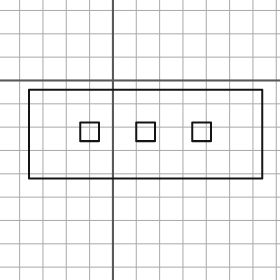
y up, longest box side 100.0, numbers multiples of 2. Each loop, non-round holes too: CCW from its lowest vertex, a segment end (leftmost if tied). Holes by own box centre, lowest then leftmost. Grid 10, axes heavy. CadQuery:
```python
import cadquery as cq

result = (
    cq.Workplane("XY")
    .moveTo(-36.0, -42.0)
    .lineTo(64.0, -42.0)
    .lineTo(64.0, -4.0)
    .lineTo(-36.0, -4.0)
    .close()
    .moveTo(-14.0, -26.0)
    .lineTo(-6.0, -26.0)
    .lineTo(-6.0, -18.0)
    .lineTo(-14.0, -18.0)
    .close()
    .moveTo(10.0, -26.0)
    .lineTo(18.0, -26.0)
    .lineTo(18.0, -18.0)
    .lineTo(10.0, -18.0)
    .close()
    .moveTo(34.0, -26.0)
    .lineTo(42.0, -26.0)
    .lineTo(42.0, -18.0)
    .lineTo(34.0, -18.0)
    .close()
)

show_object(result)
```